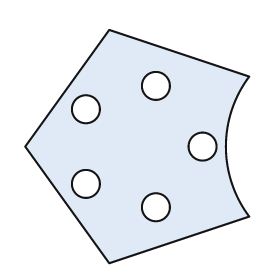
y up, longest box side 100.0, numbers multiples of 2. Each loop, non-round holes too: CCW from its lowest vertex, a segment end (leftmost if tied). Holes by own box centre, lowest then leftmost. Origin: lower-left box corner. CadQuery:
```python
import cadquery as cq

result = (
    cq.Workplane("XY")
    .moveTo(36.0, 0.0)
    .lineTo(96.0, 20.0)
    .threePointArc((86.0, 50.0), (96.0, 80.0))
    .lineTo(36.0, 100.0)
    .lineTo(0.0, 50.0)
    .close()
    .moveTo(56.0, 24.0)
    .circle(6.0)
    .moveTo(26.0, 34.0)
    .circle(6.0)
    .moveTo(76.0, 50.0)
    .circle(6.0)
    .moveTo(26.0, 66.0)
    .circle(6.0)
    .moveTo(56.0, 76.0)
    .circle(6.0)
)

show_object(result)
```